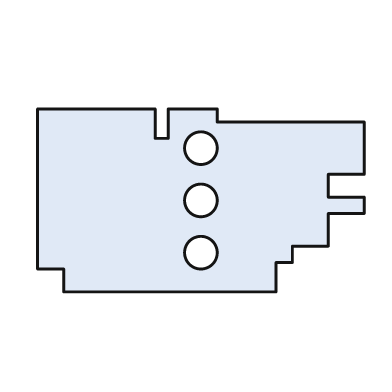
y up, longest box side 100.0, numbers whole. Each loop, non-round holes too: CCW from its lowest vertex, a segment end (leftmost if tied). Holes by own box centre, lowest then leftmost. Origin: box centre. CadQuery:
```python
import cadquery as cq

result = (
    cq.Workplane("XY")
    .moveTo(-42.0, -28.0)
    .lineTo(23.0, -28.0)
    .lineTo(23.0, -19.0)
    .lineTo(28.0, -19.0)
    .lineTo(28.0, -14.0)
    .lineTo(39.0, -14.0)
    .lineTo(39.0, -4.0)
    .lineTo(50.0, -4.0)
    .lineTo(50.0, 1.0)
    .lineTo(39.0, 1.0)
    .lineTo(39.0, 8.0)
    .lineTo(50.0, 8.0)
    .lineTo(50.0, 24.0)
    .lineTo(5.0, 24.0)
    .lineTo(5.0, 28.0)
    .lineTo(-10.0, 28.0)
    .lineTo(-10.0, 19.0)
    .lineTo(-14.0, 19.0)
    .lineTo(-14.0, 28.0)
    .lineTo(-50.0, 28.0)
    .lineTo(-50.0, -21.0)
    .lineTo(-42.0, -21.0)
    .close()
    .moveTo(0.0, -16.0)
    .circle(5.0)
    .moveTo(0.0, 0.0)
    .circle(5.0)
    .moveTo(0.0, 16.0)
    .circle(5.0)
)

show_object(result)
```